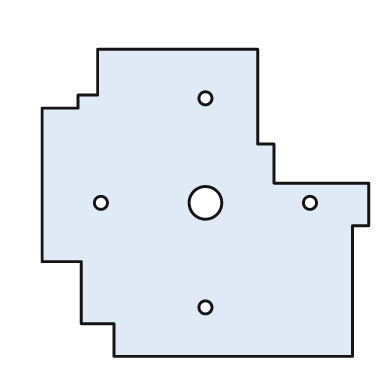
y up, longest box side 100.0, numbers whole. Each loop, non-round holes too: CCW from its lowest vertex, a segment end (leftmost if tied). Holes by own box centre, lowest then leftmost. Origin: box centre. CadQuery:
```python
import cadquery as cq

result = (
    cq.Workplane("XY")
    .moveTo(-28.0, -47.0)
    .lineTo(45.0, -47.0)
    .lineTo(45.0, -7.0)
    .lineTo(50.0, -7.0)
    .lineTo(50.0, 6.0)
    .lineTo(21.0, 6.0)
    .lineTo(21.0, 18.0)
    .lineTo(16.0, 18.0)
    .lineTo(16.0, 47.0)
    .lineTo(-33.0, 47.0)
    .lineTo(-33.0, 33.0)
    .lineTo(-39.0, 33.0)
    .lineTo(-39.0, 29.0)
    .lineTo(-50.0, 29.0)
    .lineTo(-50.0, -18.0)
    .lineTo(-38.0, -18.0)
    .lineTo(-38.0, -37.0)
    .lineTo(-28.0, -37.0)
    .close()
    .moveTo(0.0, -32.0)
    .circle(2.0)
    .moveTo(-32.0, 0.0)
    .circle(2.0)
    .moveTo(0.0, 0.0)
    .circle(5.0)
    .moveTo(32.0, 0.0)
    .circle(2.0)
    .moveTo(0.0, 32.0)
    .circle(2.0)
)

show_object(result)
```